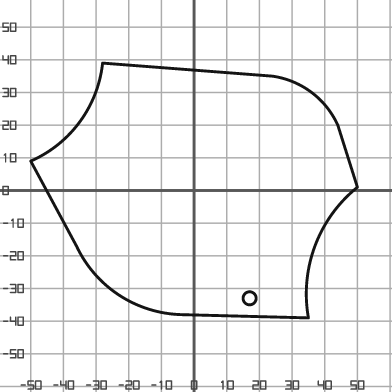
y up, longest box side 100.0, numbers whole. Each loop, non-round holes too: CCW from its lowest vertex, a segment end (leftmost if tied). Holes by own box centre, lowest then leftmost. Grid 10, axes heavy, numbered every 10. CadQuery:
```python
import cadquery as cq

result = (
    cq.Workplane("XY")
    .moveTo(35.0, -39.0)
    .threePointArc((37.0, -17.0), (50.0, 1.0))
    .lineTo(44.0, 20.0)
    .threePointArc((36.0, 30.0), (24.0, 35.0))
    .lineTo(-28.0, 39.0)
    .threePointArc((-35.0, 21.0), (-50.0, 9.0))
    .lineTo(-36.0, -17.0)
    .threePointArc((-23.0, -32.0), (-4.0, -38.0))
    .close()
    .moveTo(17.0, -33.0)
    .circle(2.0)
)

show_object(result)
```